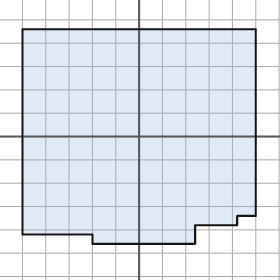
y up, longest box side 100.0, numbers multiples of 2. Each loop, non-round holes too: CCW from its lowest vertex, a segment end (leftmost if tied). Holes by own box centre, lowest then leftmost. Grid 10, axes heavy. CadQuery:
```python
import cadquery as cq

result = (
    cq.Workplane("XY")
    .moveTo(-20.0, -46.0)
    .lineTo(24.0, -46.0)
    .lineTo(24.0, -38.0)
    .lineTo(42.0, -38.0)
    .lineTo(42.0, -34.0)
    .lineTo(50.0, -34.0)
    .lineTo(50.0, 46.0)
    .lineTo(-50.0, 46.0)
    .lineTo(-50.0, -42.0)
    .lineTo(-20.0, -42.0)
    .close()
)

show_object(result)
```